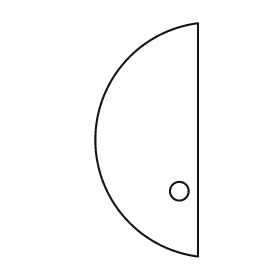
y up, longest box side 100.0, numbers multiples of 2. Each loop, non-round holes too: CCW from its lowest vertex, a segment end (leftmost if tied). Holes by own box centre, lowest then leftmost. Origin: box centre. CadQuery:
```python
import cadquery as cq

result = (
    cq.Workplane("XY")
    .moveTo(22.0, -50.0)
    .lineTo(22.0, 50.0)
    .threePointArc((-22.0, 0.0), (22.0, -50.0))
    .close()
    .moveTo(14.0, -22.0)
    .circle(4.0)
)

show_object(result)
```